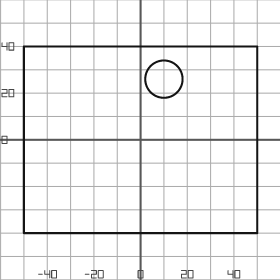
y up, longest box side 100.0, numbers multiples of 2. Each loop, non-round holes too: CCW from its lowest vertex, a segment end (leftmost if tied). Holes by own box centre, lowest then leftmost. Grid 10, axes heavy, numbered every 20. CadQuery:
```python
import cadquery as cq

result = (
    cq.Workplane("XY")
    .moveTo(-50.0, -40.0)
    .lineTo(50.0, -40.0)
    .lineTo(50.0, 40.0)
    .lineTo(-50.0, 40.0)
    .close()
    .moveTo(10.0, 26.0)
    .circle(8.0)
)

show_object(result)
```